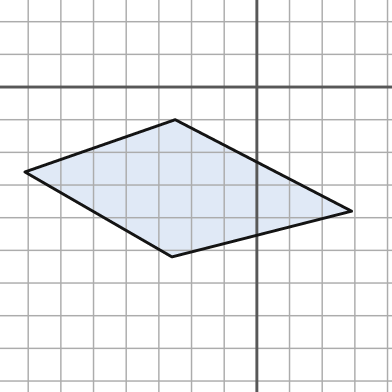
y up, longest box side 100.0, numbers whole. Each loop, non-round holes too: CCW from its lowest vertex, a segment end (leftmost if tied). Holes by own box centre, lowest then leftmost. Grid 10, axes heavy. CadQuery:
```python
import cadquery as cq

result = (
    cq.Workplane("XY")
    .moveTo(-26.0, -52.0)
    .lineTo(29.0, -38.0)
    .lineTo(-25.0, -10.0)
    .lineTo(-71.0, -26.0)
    .close()
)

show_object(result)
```